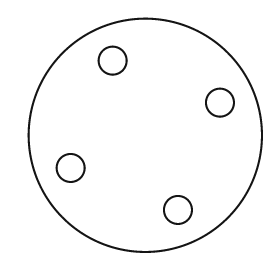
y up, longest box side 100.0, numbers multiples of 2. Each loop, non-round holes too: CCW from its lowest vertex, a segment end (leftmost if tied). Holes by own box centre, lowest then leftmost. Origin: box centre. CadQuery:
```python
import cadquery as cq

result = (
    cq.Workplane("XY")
    .moveTo(0.0, 0.0)
    .circle(50.0)
    .moveTo(14.0, -32.0)
    .circle(6.0)
    .moveTo(-32.0, -14.0)
    .circle(6.0)
    .moveTo(32.0, 14.0)
    .circle(6.0)
    .moveTo(-14.0, 32.0)
    .circle(6.0)
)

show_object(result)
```